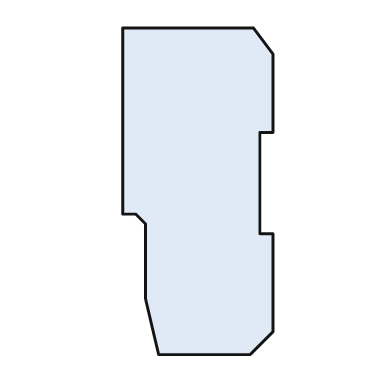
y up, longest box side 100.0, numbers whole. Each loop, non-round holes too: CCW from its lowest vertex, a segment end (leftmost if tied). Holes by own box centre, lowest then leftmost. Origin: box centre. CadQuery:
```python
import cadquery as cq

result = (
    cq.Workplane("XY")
    .moveTo(-12.0, -50.0)
    .lineTo(16.0, -50.0)
    .lineTo(23.0, -43.0)
    .lineTo(23.0, -13.0)
    .lineTo(19.0, -13.0)
    .lineTo(19.0, 18.0)
    .lineTo(23.0, 18.0)
    .lineTo(23.0, 42.0)
    .lineTo(17.0, 50.0)
    .lineTo(-23.0, 50.0)
    .lineTo(-23.0, -7.0)
    .lineTo(-19.0, -7.0)
    .lineTo(-16.0, -10.0)
    .lineTo(-16.0, -33.0)
    .close()
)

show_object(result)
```